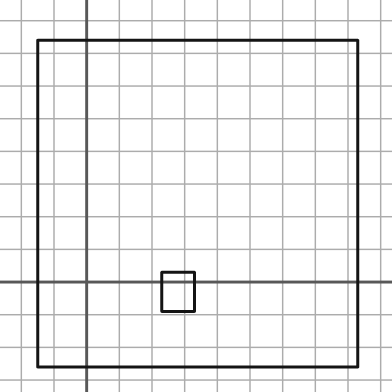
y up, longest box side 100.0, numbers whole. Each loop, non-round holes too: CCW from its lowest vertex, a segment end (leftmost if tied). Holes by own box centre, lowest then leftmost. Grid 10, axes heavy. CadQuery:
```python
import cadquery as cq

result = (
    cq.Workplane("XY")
    .moveTo(-15.0, -26.0)
    .lineTo(83.0, -26.0)
    .lineTo(83.0, 74.0)
    .lineTo(-15.0, 74.0)
    .close()
    .moveTo(23.0, -9.0)
    .lineTo(33.0, -9.0)
    .lineTo(33.0, 3.0)
    .lineTo(23.0, 3.0)
    .close()
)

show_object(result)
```